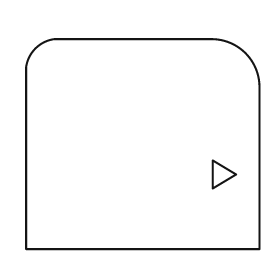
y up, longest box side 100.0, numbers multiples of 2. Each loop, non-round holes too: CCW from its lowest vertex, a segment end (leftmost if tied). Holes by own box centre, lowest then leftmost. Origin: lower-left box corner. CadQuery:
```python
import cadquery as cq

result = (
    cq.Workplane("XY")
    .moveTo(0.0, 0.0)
    .lineTo(100.0, 0.0)
    .lineTo(100.0, 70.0)
    .threePointArc((94.0, 84.0), (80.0, 90.0))
    .lineTo(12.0, 90.0)
    .threePointArc((4.0, 86.0), (0.0, 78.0))
    .close()
    .moveTo(80.0, 26.0)
    .lineTo(90.0, 32.0)
    .lineTo(80.0, 38.0)
    .close()
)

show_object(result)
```